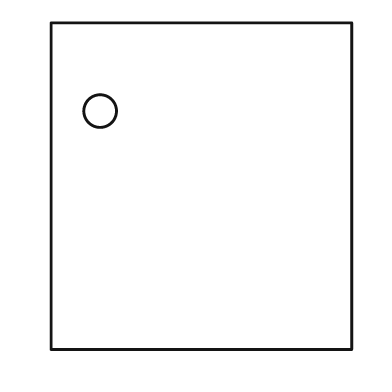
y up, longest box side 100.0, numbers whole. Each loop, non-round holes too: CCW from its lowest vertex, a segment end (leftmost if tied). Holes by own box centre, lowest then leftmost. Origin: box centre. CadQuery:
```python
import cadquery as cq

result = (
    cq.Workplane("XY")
    .moveTo(-46.0, -50.0)
    .lineTo(46.0, -50.0)
    .lineTo(46.0, 50.0)
    .lineTo(-46.0, 50.0)
    .close()
    .moveTo(-31.0, 23.0)
    .circle(5.0)
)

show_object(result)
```